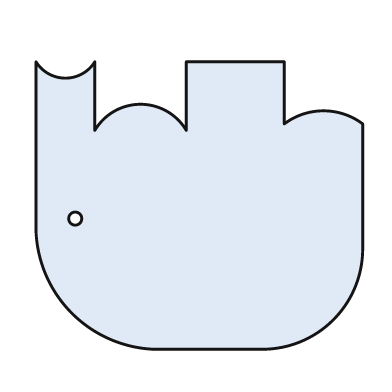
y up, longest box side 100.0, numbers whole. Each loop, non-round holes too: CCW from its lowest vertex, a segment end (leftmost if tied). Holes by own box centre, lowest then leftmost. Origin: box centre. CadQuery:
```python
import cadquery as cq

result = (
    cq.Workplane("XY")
    .moveTo(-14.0, -44.0)
    .lineTo(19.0, -44.0)
    .threePointArc((41.0, -35.0), (50.0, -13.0))
    .lineTo(50.0, 25.0)
    .threePointArc((38.0, 29.0), (26.0, 25.0))
    .lineTo(26.0, 44.0)
    .lineTo(-4.0, 44.0)
    .lineTo(-4.0, 23.0)
    .threePointArc((-18.0, 31.0), (-32.0, 23.0))
    .lineTo(-32.0, 44.0)
    .threePointArc((-41.0, 39.0), (-50.0, 44.0))
    .lineTo(-50.0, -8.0)
    .threePointArc((-39.0, -33.0), (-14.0, -44.0))
    .close()
    .moveTo(-38.0, -4.0)
    .circle(2.0)
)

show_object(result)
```